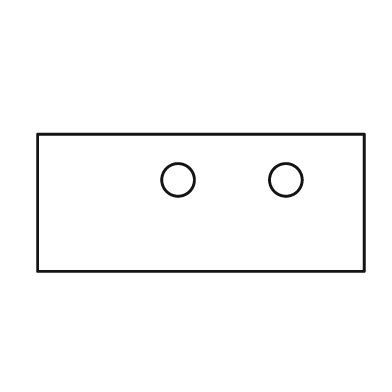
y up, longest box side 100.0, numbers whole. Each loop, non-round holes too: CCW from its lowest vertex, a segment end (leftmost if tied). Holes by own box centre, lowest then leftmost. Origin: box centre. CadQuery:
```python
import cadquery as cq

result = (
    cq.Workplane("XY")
    .moveTo(-50.0, -21.0)
    .lineTo(50.0, -21.0)
    .lineTo(50.0, 21.0)
    .lineTo(-50.0, 21.0)
    .close()
    .moveTo(-7.0, 7.0)
    .circle(5.0)
    .moveTo(26.0, 7.0)
    .circle(5.0)
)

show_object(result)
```